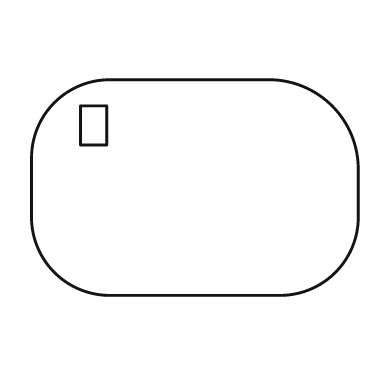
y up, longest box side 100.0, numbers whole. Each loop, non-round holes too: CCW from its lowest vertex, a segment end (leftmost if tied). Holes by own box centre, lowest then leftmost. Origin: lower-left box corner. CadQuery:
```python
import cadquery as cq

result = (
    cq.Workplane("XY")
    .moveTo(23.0, 0.0)
    .lineTo(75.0, 0.0)
    .threePointArc((93.0, 7.0), (100.0, 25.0))
    .lineTo(100.0, 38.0)
    .threePointArc((92.0, 58.0), (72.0, 66.0))
    .lineTo(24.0, 66.0)
    .threePointArc((7.0, 59.0), (0.0, 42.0))
    .lineTo(0.0, 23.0)
    .threePointArc((7.0, 7.0), (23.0, 0.0))
    .close()
    .moveTo(15.0, 46.0)
    .lineTo(23.0, 46.0)
    .lineTo(23.0, 58.0)
    .lineTo(15.0, 58.0)
    .close()
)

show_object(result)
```